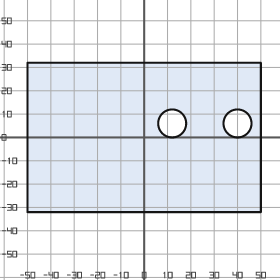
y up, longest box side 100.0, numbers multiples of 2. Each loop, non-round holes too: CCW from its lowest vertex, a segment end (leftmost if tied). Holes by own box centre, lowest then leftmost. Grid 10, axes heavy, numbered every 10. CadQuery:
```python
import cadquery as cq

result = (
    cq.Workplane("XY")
    .moveTo(-50.0, -32.0)
    .lineTo(50.0, -32.0)
    .lineTo(50.0, 32.0)
    .lineTo(-50.0, 32.0)
    .close()
    .moveTo(12.0, 6.0)
    .circle(6.0)
    .moveTo(40.0, 6.0)
    .circle(6.0)
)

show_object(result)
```